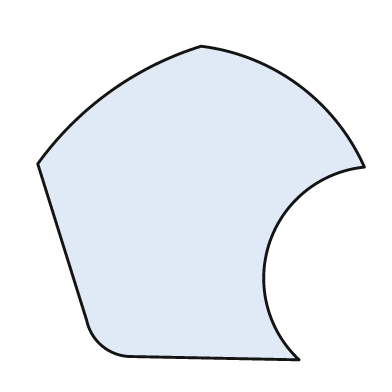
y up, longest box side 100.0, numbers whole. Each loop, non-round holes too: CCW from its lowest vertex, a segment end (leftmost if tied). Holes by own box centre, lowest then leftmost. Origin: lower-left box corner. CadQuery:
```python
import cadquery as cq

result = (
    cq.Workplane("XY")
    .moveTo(80.0, 0.0)
    .threePointArc((71.0, 36.0), (100.0, 59.0))
    .threePointArc((80.0, 84.0), (50.0, 96.0))
    .threePointArc((22.0, 82.0), (0.0, 60.0))
    .lineTo(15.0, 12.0)
    .threePointArc((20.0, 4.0), (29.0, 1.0))
    .close()
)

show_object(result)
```